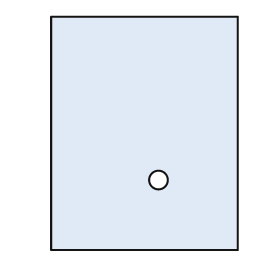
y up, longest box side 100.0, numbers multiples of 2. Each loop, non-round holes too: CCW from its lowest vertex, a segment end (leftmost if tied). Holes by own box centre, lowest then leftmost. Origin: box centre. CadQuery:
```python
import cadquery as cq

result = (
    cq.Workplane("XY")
    .moveTo(-40.0, -50.0)
    .lineTo(40.0, -50.0)
    .lineTo(40.0, 50.0)
    .lineTo(-40.0, 50.0)
    .close()
    .moveTo(6.0, -20.0)
    .circle(4.0)
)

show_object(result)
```